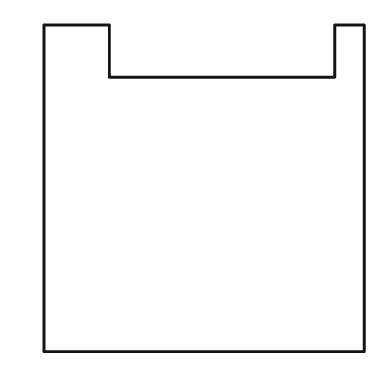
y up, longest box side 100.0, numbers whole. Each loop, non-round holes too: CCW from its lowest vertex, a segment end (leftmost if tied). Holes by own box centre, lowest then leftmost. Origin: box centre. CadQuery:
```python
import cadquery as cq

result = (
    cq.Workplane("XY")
    .moveTo(-49.0, -50.0)
    .lineTo(49.0, -50.0)
    .lineTo(49.0, 50.0)
    .lineTo(40.0, 50.0)
    .lineTo(40.0, 34.0)
    .lineTo(-29.0, 34.0)
    .lineTo(-29.0, 50.0)
    .lineTo(-49.0, 50.0)
    .close()
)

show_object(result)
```